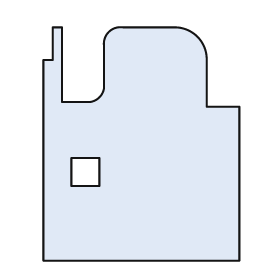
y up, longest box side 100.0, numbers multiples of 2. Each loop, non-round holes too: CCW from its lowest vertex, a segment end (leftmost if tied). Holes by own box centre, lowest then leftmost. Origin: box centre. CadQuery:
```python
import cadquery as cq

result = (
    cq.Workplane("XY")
    .moveTo(-42.0, -50.0)
    .lineTo(42.0, -50.0)
    .lineTo(42.0, 16.0)
    .lineTo(28.0, 16.0)
    .lineTo(28.0, 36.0)
    .threePointArc((24.0, 46.0), (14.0, 50.0))
    .lineTo(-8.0, 50.0)
    .threePointArc((-14.0, 48.0), (-16.0, 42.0))
    .lineTo(-16.0, 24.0)
    .threePointArc((-18.0, 20.0), (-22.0, 18.0))
    .lineTo(-34.0, 18.0)
    .lineTo(-34.0, 50.0)
    .lineTo(-38.0, 50.0)
    .lineTo(-38.0, 36.0)
    .lineTo(-42.0, 36.0)
    .close()
    .moveTo(-30.0, -18.0)
    .lineTo(-18.0, -18.0)
    .lineTo(-18.0, -6.0)
    .lineTo(-30.0, -6.0)
    .close()
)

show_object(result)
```